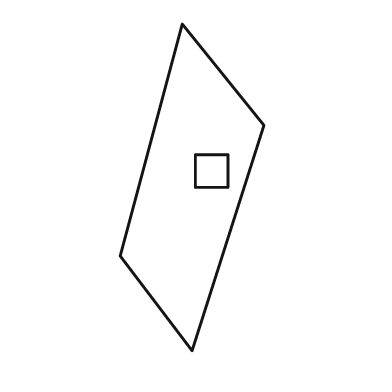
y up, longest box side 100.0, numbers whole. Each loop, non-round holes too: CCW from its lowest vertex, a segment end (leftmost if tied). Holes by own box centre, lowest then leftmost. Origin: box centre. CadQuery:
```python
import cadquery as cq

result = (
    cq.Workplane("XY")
    .moveTo(0.0, -50.0)
    .lineTo(22.0, 19.0)
    .lineTo(-3.0, 50.0)
    .lineTo(-22.0, -21.0)
    .close()
    .moveTo(1.0, 0.0)
    .lineTo(11.0, 0.0)
    .lineTo(11.0, 10.0)
    .lineTo(1.0, 10.0)
    .close()
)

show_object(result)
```